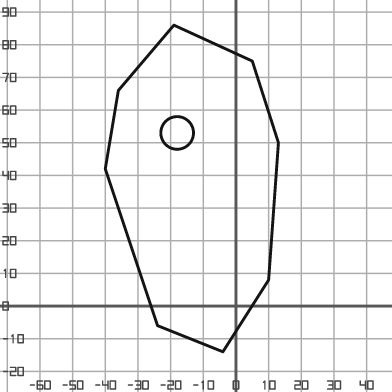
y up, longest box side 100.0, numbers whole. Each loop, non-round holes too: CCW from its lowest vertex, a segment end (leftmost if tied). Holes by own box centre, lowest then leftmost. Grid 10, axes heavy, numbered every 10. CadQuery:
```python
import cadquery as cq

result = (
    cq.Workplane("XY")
    .moveTo(-4.0, -14.0)
    .lineTo(10.0, 8.0)
    .lineTo(13.0, 50.0)
    .lineTo(5.0, 75.0)
    .lineTo(-19.0, 86.0)
    .lineTo(-36.0, 66.0)
    .lineTo(-40.0, 42.0)
    .lineTo(-24.0, -6.0)
    .close()
    .moveTo(-18.0, 53.0)
    .circle(5.0)
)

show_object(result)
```